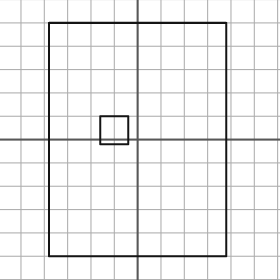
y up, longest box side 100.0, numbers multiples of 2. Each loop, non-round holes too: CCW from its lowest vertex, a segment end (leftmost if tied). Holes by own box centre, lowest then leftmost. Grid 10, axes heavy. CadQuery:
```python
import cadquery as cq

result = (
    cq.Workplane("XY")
    .moveTo(-38.0, -50.0)
    .lineTo(38.0, -50.0)
    .lineTo(38.0, 50.0)
    .lineTo(-38.0, 50.0)
    .close()
    .moveTo(-16.0, -2.0)
    .lineTo(-4.0, -2.0)
    .lineTo(-4.0, 10.0)
    .lineTo(-16.0, 10.0)
    .close()
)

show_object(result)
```